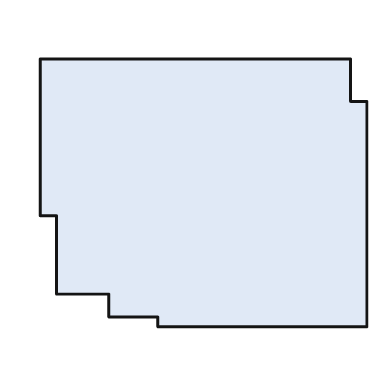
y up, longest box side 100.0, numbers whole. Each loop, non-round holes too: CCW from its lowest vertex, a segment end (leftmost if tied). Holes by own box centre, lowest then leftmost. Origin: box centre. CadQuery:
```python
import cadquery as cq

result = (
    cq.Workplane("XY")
    .moveTo(-14.0, -41.0)
    .lineTo(50.0, -41.0)
    .lineTo(50.0, 28.0)
    .lineTo(45.0, 28.0)
    .lineTo(45.0, 41.0)
    .lineTo(-50.0, 41.0)
    .lineTo(-50.0, -7.0)
    .lineTo(-45.0, -7.0)
    .lineTo(-45.0, -31.0)
    .lineTo(-29.0, -31.0)
    .lineTo(-29.0, -38.0)
    .lineTo(-14.0, -38.0)
    .close()
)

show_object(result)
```